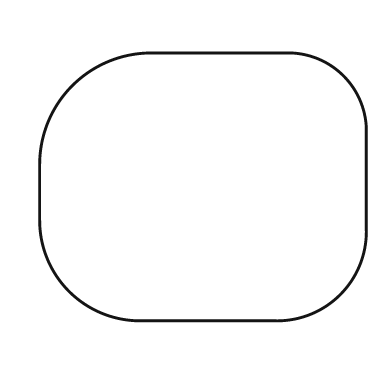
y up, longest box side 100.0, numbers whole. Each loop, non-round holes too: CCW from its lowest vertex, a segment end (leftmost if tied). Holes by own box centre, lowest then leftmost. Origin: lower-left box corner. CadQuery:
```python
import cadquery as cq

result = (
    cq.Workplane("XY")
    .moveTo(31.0, 0.0)
    .lineTo(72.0, 0.0)
    .threePointArc((92.0, 8.0), (100.0, 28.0))
    .lineTo(100.0, 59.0)
    .threePointArc((93.0, 75.0), (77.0, 82.0))
    .lineTo(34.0, 82.0)
    .threePointArc((10.0, 72.0), (0.0, 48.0))
    .lineTo(0.0, 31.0)
    .threePointArc((9.0, 9.0), (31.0, 0.0))
    .close()
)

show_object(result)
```